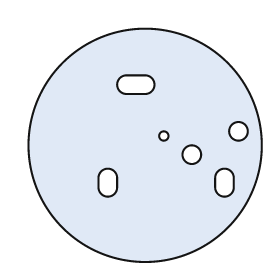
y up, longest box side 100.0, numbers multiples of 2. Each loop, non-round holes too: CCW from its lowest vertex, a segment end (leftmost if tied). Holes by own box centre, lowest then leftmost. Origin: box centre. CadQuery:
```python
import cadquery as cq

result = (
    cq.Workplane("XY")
    .moveTo(0.0, 0.0)
    .circle(50.0)
    .moveTo(-20.0, -18.0)
    .threePointArc((-16.0, -22.0), (-12.0, -18.0))
    .lineTo(-12.0, -14.0)
    .threePointArc((-16.0, -10.0), (-20.0, -14.0))
    .close()
    .moveTo(30.0, -18.0)
    .threePointArc((34.0, -22.0), (38.0, -18.0))
    .lineTo(38.0, -14.0)
    .threePointArc((34.0, -10.0), (30.0, -14.0))
    .close()
    .moveTo(20.0, -4.0)
    .circle(4.0)
    .moveTo(8.0, 4.0)
    .circle(2.0)
    .moveTo(40.0, 6.0)
    .circle(4.0)
    .moveTo(-8.0, 22.0)
    .lineTo(0.0, 22.0)
    .threePointArc((4.0, 26.0), (0.0, 30.0))
    .lineTo(-8.0, 30.0)
    .threePointArc((-12.0, 26.0), (-8.0, 22.0))
    .close()
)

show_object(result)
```